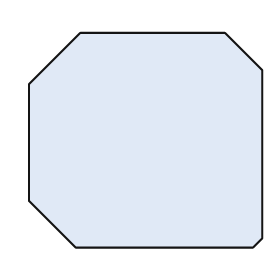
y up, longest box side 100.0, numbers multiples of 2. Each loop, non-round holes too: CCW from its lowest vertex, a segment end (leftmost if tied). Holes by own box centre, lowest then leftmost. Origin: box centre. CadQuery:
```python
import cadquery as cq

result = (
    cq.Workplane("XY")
    .moveTo(-30.0, -46.0)
    .lineTo(46.0, -46.0)
    .lineTo(50.0, -42.0)
    .lineTo(50.0, 30.0)
    .lineTo(34.0, 46.0)
    .lineTo(-28.0, 46.0)
    .lineTo(-50.0, 24.0)
    .lineTo(-50.0, -26.0)
    .close()
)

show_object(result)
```